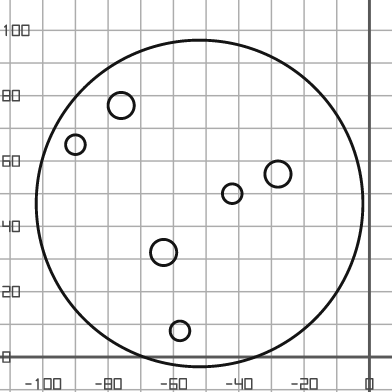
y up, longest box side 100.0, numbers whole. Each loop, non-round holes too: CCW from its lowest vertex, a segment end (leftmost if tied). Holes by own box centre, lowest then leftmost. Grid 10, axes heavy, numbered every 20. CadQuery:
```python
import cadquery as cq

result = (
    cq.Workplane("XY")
    .moveTo(-52.0, 47.0)
    .circle(50.0)
    .moveTo(-58.0, 8.0)
    .circle(3.0)
    .moveTo(-63.0, 32.0)
    .circle(4.0)
    .moveTo(-42.0, 50.0)
    .circle(3.0)
    .moveTo(-28.0, 56.0)
    .circle(4.0)
    .moveTo(-90.0, 65.0)
    .circle(3.0)
    .moveTo(-76.0, 77.0)
    .circle(4.0)
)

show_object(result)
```